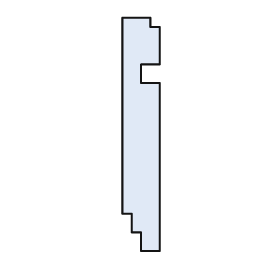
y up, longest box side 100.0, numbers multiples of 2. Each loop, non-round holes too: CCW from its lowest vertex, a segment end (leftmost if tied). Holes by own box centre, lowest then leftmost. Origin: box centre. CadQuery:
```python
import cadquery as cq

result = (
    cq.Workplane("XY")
    .moveTo(0.0, -50.0)
    .lineTo(8.0, -50.0)
    .lineTo(8.0, 22.0)
    .lineTo(0.0, 22.0)
    .lineTo(0.0, 30.0)
    .lineTo(8.0, 30.0)
    .lineTo(8.0, 46.0)
    .lineTo(4.0, 46.0)
    .lineTo(4.0, 50.0)
    .lineTo(-8.0, 50.0)
    .lineTo(-8.0, -34.0)
    .lineTo(-4.0, -34.0)
    .lineTo(-4.0, -42.0)
    .lineTo(0.0, -42.0)
    .close()
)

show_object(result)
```